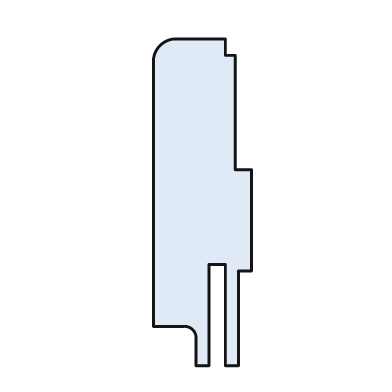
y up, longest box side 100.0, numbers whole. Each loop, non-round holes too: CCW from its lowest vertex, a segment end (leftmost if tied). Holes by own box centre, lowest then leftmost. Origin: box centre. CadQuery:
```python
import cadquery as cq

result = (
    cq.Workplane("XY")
    .moveTo(-2.0, -50.0)
    .lineTo(2.0, -50.0)
    .lineTo(2.0, -19.0)
    .lineTo(7.0, -19.0)
    .lineTo(7.0, -50.0)
    .lineTo(11.0, -50.0)
    .lineTo(11.0, -21.0)
    .lineTo(15.0, -21.0)
    .lineTo(15.0, 10.0)
    .lineTo(10.0, 10.0)
    .lineTo(10.0, 45.0)
    .lineTo(7.0, 45.0)
    .lineTo(7.0, 50.0)
    .lineTo(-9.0, 50.0)
    .threePointArc((-13.0, 48.0), (-15.0, 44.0))
    .lineTo(-15.0, -38.0)
    .lineTo(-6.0, -38.0)
    .threePointArc((-3.0, -39.0), (-2.0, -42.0))
    .close()
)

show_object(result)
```